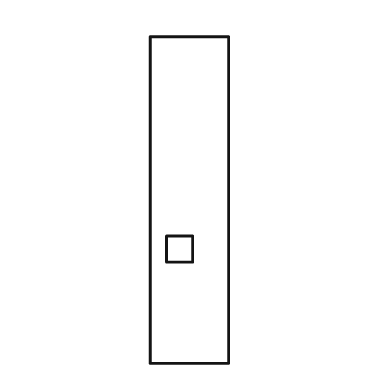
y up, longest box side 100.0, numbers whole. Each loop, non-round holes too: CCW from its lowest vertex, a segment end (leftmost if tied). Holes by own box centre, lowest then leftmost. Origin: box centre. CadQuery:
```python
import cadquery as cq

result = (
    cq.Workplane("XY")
    .moveTo(-12.0, -50.0)
    .lineTo(12.0, -50.0)
    .lineTo(12.0, 50.0)
    .lineTo(-12.0, 50.0)
    .close()
    .moveTo(-7.0, -19.0)
    .lineTo(1.0, -19.0)
    .lineTo(1.0, -11.0)
    .lineTo(-7.0, -11.0)
    .close()
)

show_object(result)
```